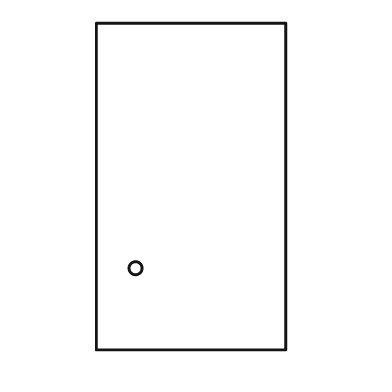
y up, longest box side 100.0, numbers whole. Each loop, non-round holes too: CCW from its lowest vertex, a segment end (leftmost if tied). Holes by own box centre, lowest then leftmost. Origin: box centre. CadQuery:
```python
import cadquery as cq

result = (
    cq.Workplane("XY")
    .moveTo(-29.0, -50.0)
    .lineTo(29.0, -50.0)
    .lineTo(29.0, 50.0)
    .lineTo(-29.0, 50.0)
    .close()
    .moveTo(-17.0, -25.0)
    .circle(2.0)
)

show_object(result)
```